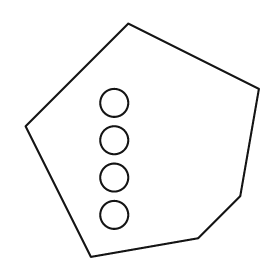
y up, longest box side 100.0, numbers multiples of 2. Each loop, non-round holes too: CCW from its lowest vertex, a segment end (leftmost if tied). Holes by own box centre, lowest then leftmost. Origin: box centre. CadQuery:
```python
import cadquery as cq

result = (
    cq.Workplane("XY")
    .moveTo(-22.0, -50.0)
    .lineTo(24.0, -42.0)
    .lineTo(42.0, -24.0)
    .lineTo(50.0, 22.0)
    .lineTo(-6.0, 50.0)
    .lineTo(-50.0, 6.0)
    .close()
    .moveTo(-12.0, -32.0)
    .circle(6.0)
    .moveTo(-12.0, -16.0)
    .circle(6.0)
    .moveTo(-12.0, 0.0)
    .circle(6.0)
    .moveTo(-12.0, 16.0)
    .circle(6.0)
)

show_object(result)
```